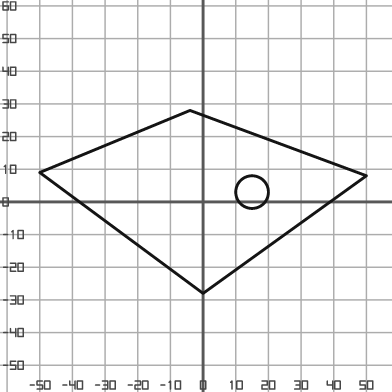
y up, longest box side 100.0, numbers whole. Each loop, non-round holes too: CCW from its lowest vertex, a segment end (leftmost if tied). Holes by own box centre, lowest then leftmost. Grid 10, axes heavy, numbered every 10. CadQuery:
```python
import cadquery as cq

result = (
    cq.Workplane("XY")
    .moveTo(0.0, -28.0)
    .lineTo(50.0, 8.0)
    .lineTo(-4.0, 28.0)
    .lineTo(-50.0, 9.0)
    .close()
    .moveTo(15.0, 3.0)
    .circle(5.0)
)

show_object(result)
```